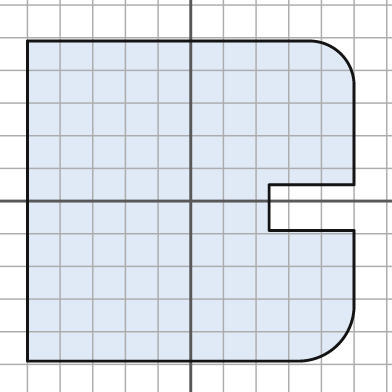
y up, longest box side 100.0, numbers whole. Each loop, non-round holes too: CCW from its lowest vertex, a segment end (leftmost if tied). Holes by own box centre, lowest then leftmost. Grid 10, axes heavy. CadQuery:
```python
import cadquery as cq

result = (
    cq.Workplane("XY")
    .moveTo(-50.0, -49.0)
    .lineTo(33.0, -49.0)
    .threePointArc((45.0, -44.0), (50.0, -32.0))
    .lineTo(50.0, -9.0)
    .lineTo(24.0, -9.0)
    .lineTo(24.0, 5.0)
    .lineTo(50.0, 5.0)
    .lineTo(50.0, 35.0)
    .threePointArc((46.0, 45.0), (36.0, 49.0))
    .lineTo(-50.0, 49.0)
    .close()
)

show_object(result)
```